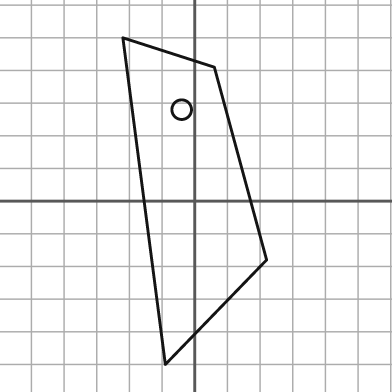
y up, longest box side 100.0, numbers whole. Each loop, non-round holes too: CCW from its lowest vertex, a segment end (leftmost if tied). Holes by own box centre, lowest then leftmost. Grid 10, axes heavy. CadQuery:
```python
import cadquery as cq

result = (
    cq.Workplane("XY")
    .moveTo(-9.0, -50.0)
    .lineTo(22.0, -18.0)
    .lineTo(6.0, 41.0)
    .lineTo(-22.0, 50.0)
    .close()
    .moveTo(-4.0, 28.0)
    .circle(3.0)
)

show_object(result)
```